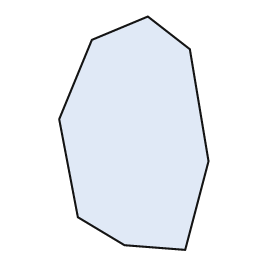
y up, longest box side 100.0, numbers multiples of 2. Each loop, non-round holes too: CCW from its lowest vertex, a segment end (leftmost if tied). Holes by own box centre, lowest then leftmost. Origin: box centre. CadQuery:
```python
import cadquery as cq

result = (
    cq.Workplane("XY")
    .moveTo(22.0, -50.0)
    .lineTo(32.0, -12.0)
    .lineTo(24.0, 36.0)
    .lineTo(6.0, 50.0)
    .lineTo(-18.0, 40.0)
    .lineTo(-32.0, 6.0)
    .lineTo(-24.0, -36.0)
    .lineTo(-4.0, -48.0)
    .close()
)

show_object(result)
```